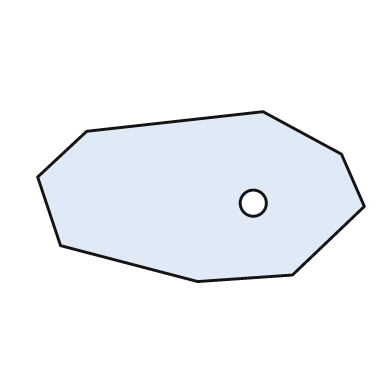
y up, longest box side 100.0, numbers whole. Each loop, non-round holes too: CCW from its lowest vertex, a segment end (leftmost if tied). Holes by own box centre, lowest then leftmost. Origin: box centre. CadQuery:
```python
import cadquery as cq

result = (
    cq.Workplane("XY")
    .moveTo(-1.0, -26.0)
    .lineTo(28.0, -24.0)
    .lineTo(50.0, -3.0)
    .lineTo(43.0, 13.0)
    .lineTo(19.0, 26.0)
    .lineTo(-35.0, 20.0)
    .lineTo(-50.0, 6.0)
    .lineTo(-43.0, -15.0)
    .close()
    .moveTo(16.0, -2.0)
    .circle(4.0)
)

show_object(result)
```